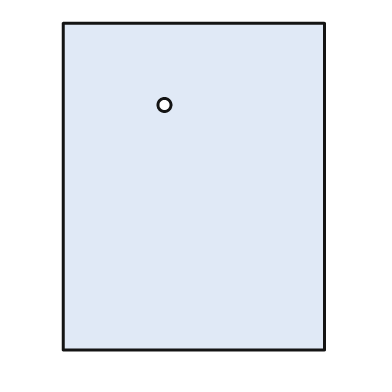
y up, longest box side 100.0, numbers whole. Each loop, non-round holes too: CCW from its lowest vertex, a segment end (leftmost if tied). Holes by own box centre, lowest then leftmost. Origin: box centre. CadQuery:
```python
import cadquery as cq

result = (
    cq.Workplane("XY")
    .moveTo(-40.0, -50.0)
    .lineTo(40.0, -50.0)
    .lineTo(40.0, 50.0)
    .lineTo(-40.0, 50.0)
    .close()
    .moveTo(-9.0, 25.0)
    .circle(2.0)
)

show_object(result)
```